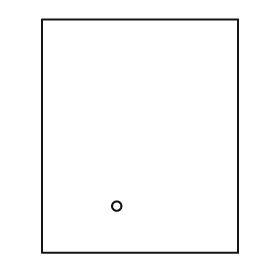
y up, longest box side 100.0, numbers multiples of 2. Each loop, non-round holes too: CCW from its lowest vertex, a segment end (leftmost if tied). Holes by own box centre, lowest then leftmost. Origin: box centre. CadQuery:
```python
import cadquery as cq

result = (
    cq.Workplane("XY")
    .moveTo(-42.0, -50.0)
    .lineTo(42.0, -50.0)
    .lineTo(42.0, 50.0)
    .lineTo(-42.0, 50.0)
    .close()
    .moveTo(-10.0, -30.0)
    .circle(2.0)
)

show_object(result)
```